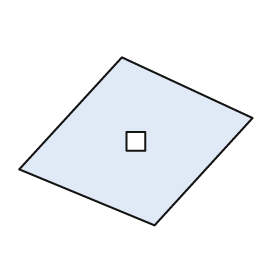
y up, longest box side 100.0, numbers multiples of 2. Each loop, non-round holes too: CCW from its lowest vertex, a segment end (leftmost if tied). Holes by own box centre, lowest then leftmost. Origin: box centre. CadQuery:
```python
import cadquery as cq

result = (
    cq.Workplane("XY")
    .moveTo(8.0, -36.0)
    .lineTo(50.0, 10.0)
    .lineTo(-6.0, 36.0)
    .lineTo(-50.0, -12.0)
    .close()
    .moveTo(-4.0, -4.0)
    .lineTo(4.0, -4.0)
    .lineTo(4.0, 4.0)
    .lineTo(-4.0, 4.0)
    .close()
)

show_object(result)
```